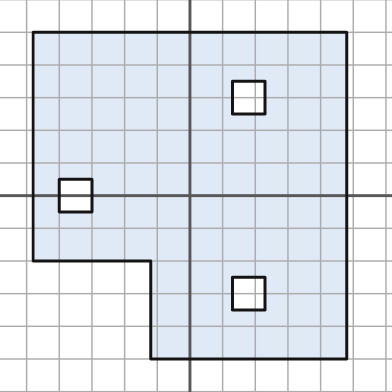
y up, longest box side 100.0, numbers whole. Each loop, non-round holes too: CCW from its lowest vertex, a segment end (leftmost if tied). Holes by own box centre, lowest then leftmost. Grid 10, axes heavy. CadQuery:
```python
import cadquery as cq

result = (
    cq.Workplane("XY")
    .moveTo(-12.0, -50.0)
    .lineTo(48.0, -50.0)
    .lineTo(48.0, 50.0)
    .lineTo(-48.0, 50.0)
    .lineTo(-48.0, -20.0)
    .lineTo(-12.0, -20.0)
    .close()
    .moveTo(13.0, -35.0)
    .lineTo(23.0, -35.0)
    .lineTo(23.0, -25.0)
    .lineTo(13.0, -25.0)
    .close()
    .moveTo(-40.0, -5.0)
    .lineTo(-30.0, -5.0)
    .lineTo(-30.0, 5.0)
    .lineTo(-40.0, 5.0)
    .close()
    .moveTo(13.0, 25.0)
    .lineTo(23.0, 25.0)
    .lineTo(23.0, 35.0)
    .lineTo(13.0, 35.0)
    .close()
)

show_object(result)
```